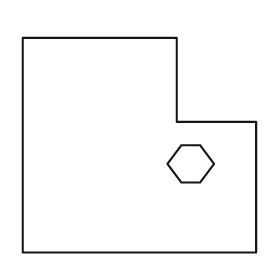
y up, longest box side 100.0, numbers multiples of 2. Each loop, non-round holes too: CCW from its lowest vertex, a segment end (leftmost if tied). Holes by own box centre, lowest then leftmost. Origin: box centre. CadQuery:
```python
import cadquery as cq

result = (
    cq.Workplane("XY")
    .moveTo(-50.0, -46.0)
    .lineTo(50.0, -46.0)
    .lineTo(50.0, 10.0)
    .lineTo(16.0, 10.0)
    .lineTo(16.0, 46.0)
    .lineTo(-50.0, 46.0)
    .close()
    .moveTo(18.0, -16.0)
    .lineTo(26.0, -16.0)
    .lineTo(32.0, -8.0)
    .lineTo(26.0, 0.0)
    .lineTo(18.0, 0.0)
    .lineTo(12.0, -8.0)
    .close()
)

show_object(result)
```